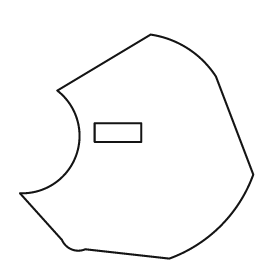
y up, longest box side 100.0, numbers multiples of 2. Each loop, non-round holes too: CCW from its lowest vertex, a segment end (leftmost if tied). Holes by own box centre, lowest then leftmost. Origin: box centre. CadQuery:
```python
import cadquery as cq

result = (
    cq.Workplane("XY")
    .moveTo(14.0, -48.0)
    .threePointArc((36.0, -34.0), (50.0, -12.0))
    .lineTo(34.0, 30.0)
    .threePointArc((22.0, 42.0), (6.0, 48.0))
    .lineTo(-34.0, 24.0)
    .threePointArc((-26.0, -4.0), (-50.0, -20.0))
    .lineTo(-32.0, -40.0)
    .threePointArc((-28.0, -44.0), (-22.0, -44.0))
    .close()
    .moveTo(-18.0, 2.0)
    .lineTo(2.0, 2.0)
    .lineTo(2.0, 10.0)
    .lineTo(-18.0, 10.0)
    .close()
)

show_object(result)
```